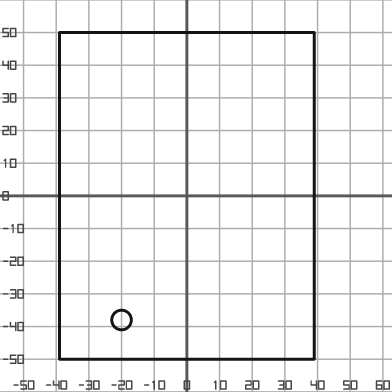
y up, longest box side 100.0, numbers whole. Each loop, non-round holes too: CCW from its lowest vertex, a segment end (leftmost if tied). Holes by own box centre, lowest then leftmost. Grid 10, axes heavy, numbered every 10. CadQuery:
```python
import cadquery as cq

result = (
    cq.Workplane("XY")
    .moveTo(-39.0, -50.0)
    .lineTo(39.0, -50.0)
    .lineTo(39.0, 50.0)
    .lineTo(-39.0, 50.0)
    .close()
    .moveTo(-20.0, -38.0)
    .circle(3.0)
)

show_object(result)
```